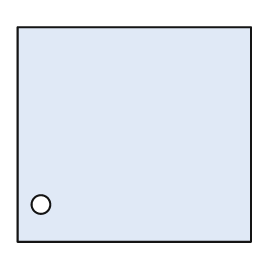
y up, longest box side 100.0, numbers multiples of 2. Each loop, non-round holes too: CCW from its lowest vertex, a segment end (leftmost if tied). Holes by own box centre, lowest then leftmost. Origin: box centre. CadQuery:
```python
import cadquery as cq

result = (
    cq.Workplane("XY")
    .moveTo(-50.0, -46.0)
    .lineTo(50.0, -46.0)
    .lineTo(50.0, 46.0)
    .lineTo(-50.0, 46.0)
    .close()
    .moveTo(-40.0, -30.0)
    .circle(4.0)
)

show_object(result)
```